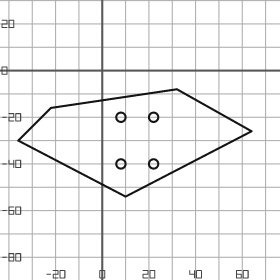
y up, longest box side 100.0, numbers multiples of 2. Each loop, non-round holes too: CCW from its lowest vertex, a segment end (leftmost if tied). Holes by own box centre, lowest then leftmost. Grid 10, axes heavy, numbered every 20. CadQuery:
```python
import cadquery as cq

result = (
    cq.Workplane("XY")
    .moveTo(10.0, -54.0)
    .lineTo(64.0, -26.0)
    .lineTo(32.0, -8.0)
    .lineTo(-22.0, -16.0)
    .lineTo(-36.0, -30.0)
    .close()
    .moveTo(8.0, -40.0)
    .circle(2.0)
    .moveTo(22.0, -40.0)
    .circle(2.0)
    .moveTo(8.0, -20.0)
    .circle(2.0)
    .moveTo(22.0, -20.0)
    .circle(2.0)
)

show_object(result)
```